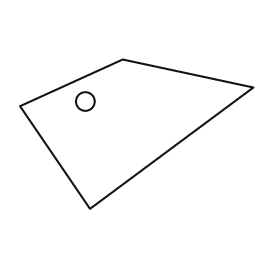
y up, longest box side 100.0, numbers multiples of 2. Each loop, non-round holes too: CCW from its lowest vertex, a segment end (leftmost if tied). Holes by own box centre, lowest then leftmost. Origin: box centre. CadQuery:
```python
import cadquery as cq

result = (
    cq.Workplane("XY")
    .moveTo(-20.0, -32.0)
    .lineTo(50.0, 20.0)
    .lineTo(-6.0, 32.0)
    .lineTo(-50.0, 12.0)
    .close()
    .moveTo(-22.0, 14.0)
    .circle(4.0)
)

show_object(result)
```